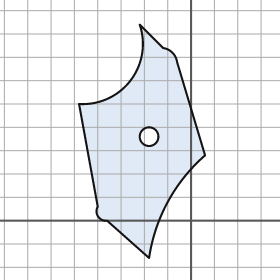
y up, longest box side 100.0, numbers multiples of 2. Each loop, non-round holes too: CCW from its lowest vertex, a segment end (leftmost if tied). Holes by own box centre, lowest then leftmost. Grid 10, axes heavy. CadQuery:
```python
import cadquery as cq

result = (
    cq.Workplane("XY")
    .moveTo(-18.0, -16.0)
    .threePointArc((-10.0, 8.0), (6.0, 28.0))
    .lineTo(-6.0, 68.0)
    .threePointArc((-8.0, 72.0), (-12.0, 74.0))
    .lineTo(-22.0, 84.0)
    .threePointArc((-26.0, 60.0), (-48.0, 50.0))
    .lineTo(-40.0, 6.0)
    .threePointArc((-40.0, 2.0), (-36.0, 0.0))
    .close()
    .moveTo(-18.0, 36.0)
    .circle(4.0)
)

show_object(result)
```